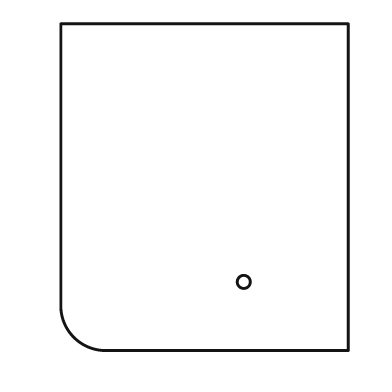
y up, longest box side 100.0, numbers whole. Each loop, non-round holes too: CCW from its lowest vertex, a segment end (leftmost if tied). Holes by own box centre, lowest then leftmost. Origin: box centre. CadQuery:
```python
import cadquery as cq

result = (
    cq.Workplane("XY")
    .moveTo(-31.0, -50.0)
    .lineTo(44.0, -50.0)
    .lineTo(44.0, 50.0)
    .lineTo(-44.0, 50.0)
    .lineTo(-44.0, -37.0)
    .threePointArc((-40.0, -46.0), (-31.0, -50.0))
    .close()
    .moveTo(12.0, -29.0)
    .circle(2.0)
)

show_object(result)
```